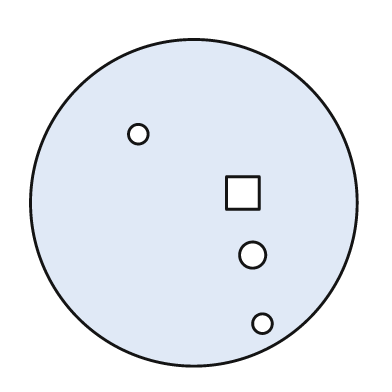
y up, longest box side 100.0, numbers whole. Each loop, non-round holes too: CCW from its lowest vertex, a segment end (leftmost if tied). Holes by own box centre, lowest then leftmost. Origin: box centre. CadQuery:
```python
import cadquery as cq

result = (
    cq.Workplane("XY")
    .moveTo(0.0, 0.0)
    .circle(50.0)
    .moveTo(21.0, -37.0)
    .circle(3.0)
    .moveTo(18.0, -16.0)
    .circle(4.0)
    .moveTo(10.0, -2.0)
    .lineTo(20.0, -2.0)
    .lineTo(20.0, 8.0)
    .lineTo(10.0, 8.0)
    .close()
    .moveTo(-17.0, 21.0)
    .circle(3.0)
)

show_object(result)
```